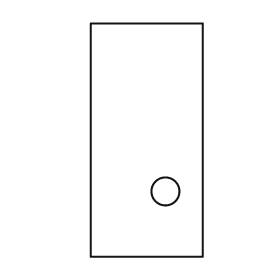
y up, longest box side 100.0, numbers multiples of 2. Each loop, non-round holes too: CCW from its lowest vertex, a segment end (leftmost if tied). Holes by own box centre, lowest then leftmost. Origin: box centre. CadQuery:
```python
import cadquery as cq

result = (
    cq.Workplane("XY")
    .moveTo(-24.0, -50.0)
    .lineTo(24.0, -50.0)
    .lineTo(24.0, 50.0)
    .lineTo(-24.0, 50.0)
    .close()
    .moveTo(8.0, -22.0)
    .circle(6.0)
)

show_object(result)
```